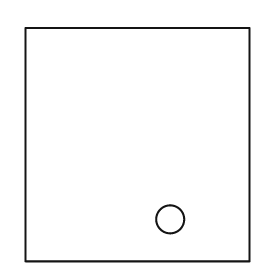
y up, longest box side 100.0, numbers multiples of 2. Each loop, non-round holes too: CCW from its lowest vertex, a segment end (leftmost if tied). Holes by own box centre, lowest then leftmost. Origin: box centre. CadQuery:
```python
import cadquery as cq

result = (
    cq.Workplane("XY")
    .moveTo(-48.0, -50.0)
    .lineTo(48.0, -50.0)
    .lineTo(48.0, 50.0)
    .lineTo(-48.0, 50.0)
    .close()
    .moveTo(14.0, -32.0)
    .circle(6.0)
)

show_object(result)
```